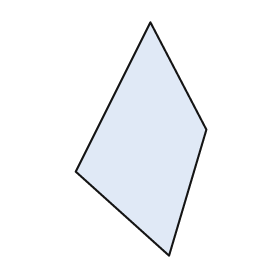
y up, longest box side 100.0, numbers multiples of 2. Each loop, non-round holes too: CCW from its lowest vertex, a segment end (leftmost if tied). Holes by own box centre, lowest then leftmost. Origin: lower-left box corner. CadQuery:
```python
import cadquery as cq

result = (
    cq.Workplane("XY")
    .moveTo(40.0, 0.0)
    .lineTo(56.0, 54.0)
    .lineTo(32.0, 100.0)
    .lineTo(0.0, 36.0)
    .close()
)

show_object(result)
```